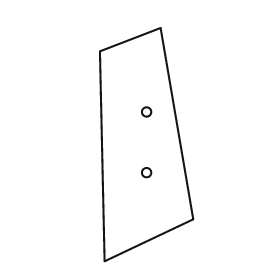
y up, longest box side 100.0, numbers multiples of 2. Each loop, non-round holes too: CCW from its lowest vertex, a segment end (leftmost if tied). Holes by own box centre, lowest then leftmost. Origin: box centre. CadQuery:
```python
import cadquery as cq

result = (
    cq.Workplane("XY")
    .moveTo(-18.0, -50.0)
    .lineTo(20.0, -32.0)
    .lineTo(6.0, 50.0)
    .lineTo(-20.0, 40.0)
    .close()
    .moveTo(0.0, -12.0)
    .circle(2.0)
    .moveTo(0.0, 14.0)
    .circle(2.0)
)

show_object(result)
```